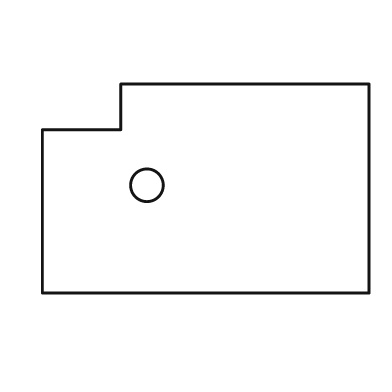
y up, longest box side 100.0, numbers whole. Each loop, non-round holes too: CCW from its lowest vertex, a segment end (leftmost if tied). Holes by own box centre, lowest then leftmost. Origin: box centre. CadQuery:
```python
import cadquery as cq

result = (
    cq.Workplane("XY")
    .moveTo(-50.0, -32.0)
    .lineTo(50.0, -32.0)
    .lineTo(50.0, 32.0)
    .lineTo(-26.0, 32.0)
    .lineTo(-26.0, 18.0)
    .lineTo(-50.0, 18.0)
    .close()
    .moveTo(-18.0, 1.0)
    .circle(5.0)
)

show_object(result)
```